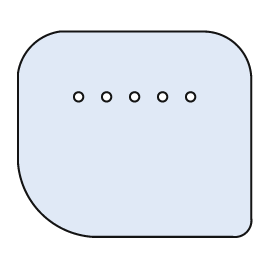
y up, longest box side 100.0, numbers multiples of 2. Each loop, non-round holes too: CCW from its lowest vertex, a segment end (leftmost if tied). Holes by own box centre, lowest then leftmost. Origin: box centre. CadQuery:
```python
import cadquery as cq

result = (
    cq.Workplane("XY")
    .moveTo(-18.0, -44.0)
    .lineTo(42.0, -44.0)
    .threePointArc((48.0, -42.0), (50.0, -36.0))
    .lineTo(50.0, 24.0)
    .threePointArc((44.0, 38.0), (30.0, 44.0))
    .lineTo(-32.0, 44.0)
    .threePointArc((-44.0, 38.0), (-50.0, 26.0))
    .lineTo(-50.0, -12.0)
    .threePointArc((-40.0, -34.0), (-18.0, -44.0))
    .close()
    .moveTo(-24.0, 16.0)
    .circle(2.0)
    .moveTo(-12.0, 16.0)
    .circle(2.0)
    .moveTo(0.0, 16.0)
    .circle(2.0)
    .moveTo(12.0, 16.0)
    .circle(2.0)
    .moveTo(24.0, 16.0)
    .circle(2.0)
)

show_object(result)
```